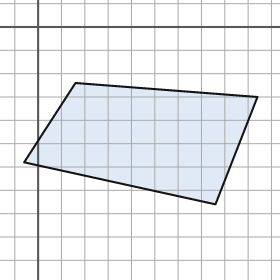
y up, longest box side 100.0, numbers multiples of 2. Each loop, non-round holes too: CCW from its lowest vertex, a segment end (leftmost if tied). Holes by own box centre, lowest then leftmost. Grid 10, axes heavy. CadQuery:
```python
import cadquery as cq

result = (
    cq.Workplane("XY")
    .moveTo(76.0, -76.0)
    .lineTo(94.0, -30.0)
    .lineTo(16.0, -24.0)
    .lineTo(-6.0, -58.0)
    .close()
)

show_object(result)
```